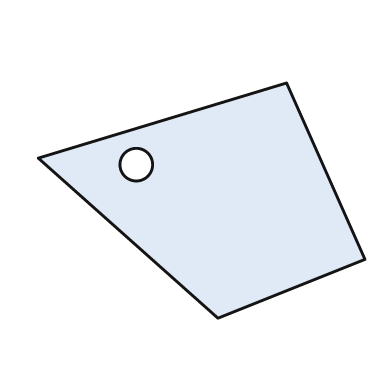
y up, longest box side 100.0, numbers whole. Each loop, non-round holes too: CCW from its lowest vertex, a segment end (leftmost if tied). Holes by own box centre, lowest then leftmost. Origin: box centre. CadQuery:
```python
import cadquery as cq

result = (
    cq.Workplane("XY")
    .moveTo(5.0, -36.0)
    .lineTo(50.0, -18.0)
    .lineTo(26.0, 36.0)
    .lineTo(-50.0, 13.0)
    .close()
    .moveTo(-20.0, 11.0)
    .circle(5.0)
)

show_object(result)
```